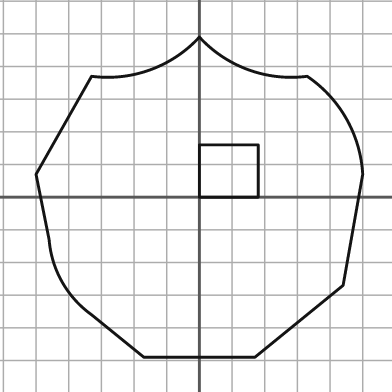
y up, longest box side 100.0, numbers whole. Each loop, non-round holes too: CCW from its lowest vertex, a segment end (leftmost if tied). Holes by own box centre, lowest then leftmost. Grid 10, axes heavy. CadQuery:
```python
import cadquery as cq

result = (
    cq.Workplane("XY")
    .moveTo(-17.0, -49.0)
    .lineTo(17.0, -49.0)
    .lineTo(44.0, -27.0)
    .lineTo(50.0, 7.0)
    .threePointArc((45.0, 24.0), (33.0, 37.0))
    .threePointArc((15.0, 39.0), (0.0, 49.0))
    .threePointArc((-15.0, 39.0), (-33.0, 37.0))
    .lineTo(-50.0, 7.0)
    .lineTo(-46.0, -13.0)
    .threePointArc((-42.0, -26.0), (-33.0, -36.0))
    .close()
    .moveTo(0.0, 0.0)
    .lineTo(18.0, 0.0)
    .lineTo(18.0, 16.0)
    .lineTo(0.0, 16.0)
    .close()
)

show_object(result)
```